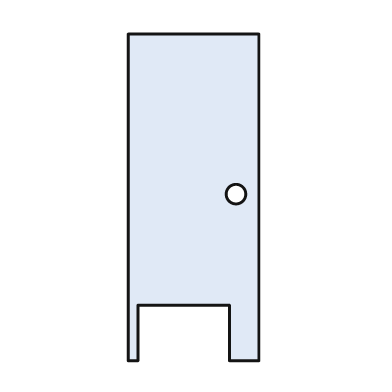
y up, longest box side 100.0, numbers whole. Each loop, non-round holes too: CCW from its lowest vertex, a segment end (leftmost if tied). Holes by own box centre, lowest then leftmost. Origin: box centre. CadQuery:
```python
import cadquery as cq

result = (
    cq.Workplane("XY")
    .moveTo(-20.0, -50.0)
    .lineTo(-17.0, -50.0)
    .lineTo(-17.0, -33.0)
    .lineTo(11.0, -33.0)
    .lineTo(11.0, -50.0)
    .lineTo(20.0, -50.0)
    .lineTo(20.0, 50.0)
    .lineTo(-20.0, 50.0)
    .close()
    .moveTo(13.0, 1.0)
    .circle(3.0)
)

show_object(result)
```